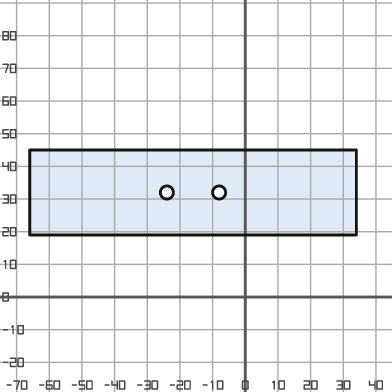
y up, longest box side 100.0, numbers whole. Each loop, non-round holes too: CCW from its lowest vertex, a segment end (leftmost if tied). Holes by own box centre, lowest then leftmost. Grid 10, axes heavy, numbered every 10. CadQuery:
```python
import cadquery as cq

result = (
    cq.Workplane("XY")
    .moveTo(-66.0, 19.0)
    .lineTo(34.0, 19.0)
    .lineTo(34.0, 45.0)
    .lineTo(-66.0, 45.0)
    .close()
    .moveTo(-24.0, 32.0)
    .circle(2.0)
    .moveTo(-8.0, 32.0)
    .circle(2.0)
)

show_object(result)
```